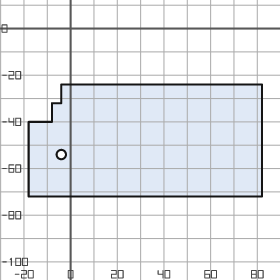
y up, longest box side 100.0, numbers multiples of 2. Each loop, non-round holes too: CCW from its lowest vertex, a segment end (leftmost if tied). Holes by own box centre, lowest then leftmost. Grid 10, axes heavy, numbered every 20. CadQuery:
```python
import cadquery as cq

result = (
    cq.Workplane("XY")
    .moveTo(-18.0, -72.0)
    .lineTo(82.0, -72.0)
    .lineTo(82.0, -24.0)
    .lineTo(-4.0, -24.0)
    .lineTo(-4.0, -32.0)
    .lineTo(-8.0, -32.0)
    .lineTo(-8.0, -40.0)
    .lineTo(-18.0, -40.0)
    .close()
    .moveTo(-4.0, -54.0)
    .circle(2.0)
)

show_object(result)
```